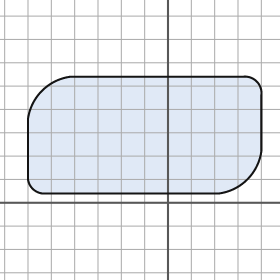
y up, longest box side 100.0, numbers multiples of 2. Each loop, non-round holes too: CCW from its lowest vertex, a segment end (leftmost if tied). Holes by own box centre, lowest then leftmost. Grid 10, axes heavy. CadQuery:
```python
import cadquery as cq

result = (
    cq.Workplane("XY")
    .moveTo(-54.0, 4.0)
    .lineTo(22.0, 4.0)
    .threePointArc((34.0, 10.0), (40.0, 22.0))
    .lineTo(40.0, 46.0)
    .threePointArc((38.0, 52.0), (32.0, 54.0))
    .lineTo(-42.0, 54.0)
    .threePointArc((-54.0, 48.0), (-60.0, 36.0))
    .lineTo(-60.0, 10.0)
    .threePointArc((-58.0, 6.0), (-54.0, 4.0))
    .close()
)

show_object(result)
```